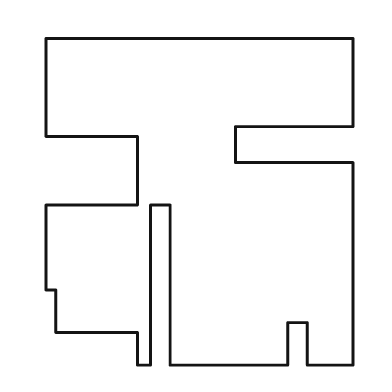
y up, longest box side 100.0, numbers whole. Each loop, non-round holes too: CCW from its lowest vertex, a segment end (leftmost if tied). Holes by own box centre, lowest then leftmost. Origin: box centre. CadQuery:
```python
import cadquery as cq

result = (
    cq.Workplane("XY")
    .moveTo(-19.0, -50.0)
    .lineTo(-15.0, -50.0)
    .lineTo(-15.0, -1.0)
    .lineTo(-9.0, -1.0)
    .lineTo(-9.0, -50.0)
    .lineTo(27.0, -50.0)
    .lineTo(27.0, -37.0)
    .lineTo(33.0, -37.0)
    .lineTo(33.0, -50.0)
    .lineTo(47.0, -50.0)
    .lineTo(47.0, 12.0)
    .lineTo(11.0, 12.0)
    .lineTo(11.0, 23.0)
    .lineTo(47.0, 23.0)
    .lineTo(47.0, 50.0)
    .lineTo(-47.0, 50.0)
    .lineTo(-47.0, 20.0)
    .lineTo(-19.0, 20.0)
    .lineTo(-19.0, -1.0)
    .lineTo(-47.0, -1.0)
    .lineTo(-47.0, -27.0)
    .lineTo(-44.0, -27.0)
    .lineTo(-44.0, -40.0)
    .lineTo(-19.0, -40.0)
    .close()
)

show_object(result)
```